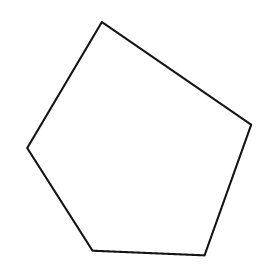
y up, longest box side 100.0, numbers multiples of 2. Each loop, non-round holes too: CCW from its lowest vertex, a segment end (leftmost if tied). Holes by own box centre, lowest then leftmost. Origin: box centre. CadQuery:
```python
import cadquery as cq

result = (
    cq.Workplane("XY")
    .moveTo(28.0, -50.0)
    .lineTo(48.0, 6.0)
    .lineTo(-16.0, 50.0)
    .lineTo(-48.0, -4.0)
    .lineTo(-20.0, -48.0)
    .close()
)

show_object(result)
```